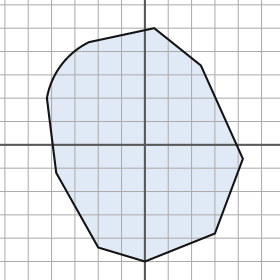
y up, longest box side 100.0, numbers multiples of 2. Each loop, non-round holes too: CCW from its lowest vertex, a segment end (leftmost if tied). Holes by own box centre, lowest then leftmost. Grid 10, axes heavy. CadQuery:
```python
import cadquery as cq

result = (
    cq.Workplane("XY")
    .moveTo(0.0, -50.0)
    .lineTo(30.0, -38.0)
    .lineTo(42.0, -6.0)
    .lineTo(24.0, 34.0)
    .lineTo(4.0, 50.0)
    .lineTo(-24.0, 44.0)
    .threePointArc((-36.0, 34.0), (-42.0, 20.0))
    .lineTo(-38.0, -12.0)
    .lineTo(-20.0, -44.0)
    .close()
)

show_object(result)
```